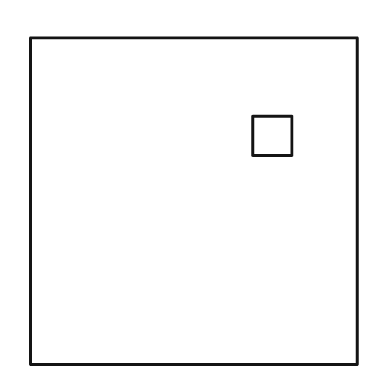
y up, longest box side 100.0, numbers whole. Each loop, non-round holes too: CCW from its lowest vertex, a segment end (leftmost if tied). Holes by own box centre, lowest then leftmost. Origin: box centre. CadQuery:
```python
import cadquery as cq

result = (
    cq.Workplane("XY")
    .moveTo(-50.0, -50.0)
    .lineTo(50.0, -50.0)
    .lineTo(50.0, 50.0)
    .lineTo(-50.0, 50.0)
    .close()
    .moveTo(18.0, 14.0)
    .lineTo(30.0, 14.0)
    .lineTo(30.0, 26.0)
    .lineTo(18.0, 26.0)
    .close()
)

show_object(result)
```